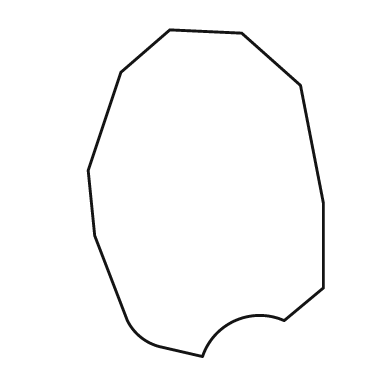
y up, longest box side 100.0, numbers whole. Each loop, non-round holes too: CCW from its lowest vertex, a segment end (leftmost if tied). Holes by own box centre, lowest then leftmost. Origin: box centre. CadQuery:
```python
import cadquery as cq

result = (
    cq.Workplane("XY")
    .moveTo(-1.0, -50.0)
    .threePointArc((9.0, -39.0), (24.0, -39.0))
    .lineTo(36.0, -29.0)
    .lineTo(36.0, -3.0)
    .lineTo(29.0, 33.0)
    .lineTo(11.0, 49.0)
    .lineTo(-11.0, 50.0)
    .lineTo(-26.0, 37.0)
    .lineTo(-36.0, 7.0)
    .lineTo(-34.0, -13.0)
    .lineTo(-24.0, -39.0)
    .threePointArc((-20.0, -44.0), (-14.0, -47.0))
    .close()
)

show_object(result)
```